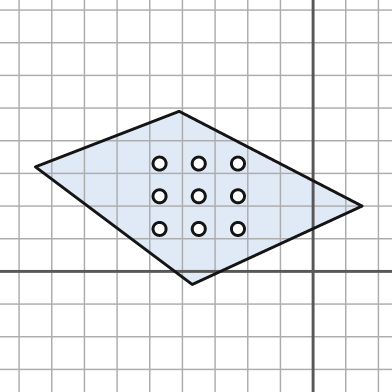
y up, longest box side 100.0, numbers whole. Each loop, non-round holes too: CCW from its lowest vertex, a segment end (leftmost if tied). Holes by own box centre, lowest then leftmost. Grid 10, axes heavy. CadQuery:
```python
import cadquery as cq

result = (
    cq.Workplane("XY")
    .moveTo(-37.0, -4.0)
    .lineTo(15.0, 20.0)
    .lineTo(-41.0, 49.0)
    .lineTo(-85.0, 32.0)
    .close()
    .moveTo(-47.0, 13.0)
    .circle(2.0)
    .moveTo(-35.0, 13.0)
    .circle(2.0)
    .moveTo(-23.0, 13.0)
    .circle(2.0)
    .moveTo(-47.0, 23.0)
    .circle(2.0)
    .moveTo(-35.0, 23.0)
    .circle(2.0)
    .moveTo(-23.0, 23.0)
    .circle(2.0)
    .moveTo(-47.0, 33.0)
    .circle(2.0)
    .moveTo(-35.0, 33.0)
    .circle(2.0)
    .moveTo(-23.0, 33.0)
    .circle(2.0)
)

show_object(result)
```